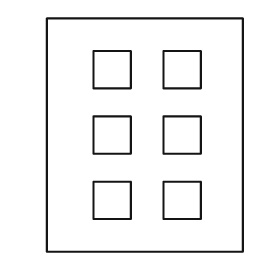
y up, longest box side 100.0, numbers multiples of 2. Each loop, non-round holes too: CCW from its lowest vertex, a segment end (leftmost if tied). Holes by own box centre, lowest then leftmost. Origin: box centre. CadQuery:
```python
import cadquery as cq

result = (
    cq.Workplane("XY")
    .moveTo(-42.0, -50.0)
    .lineTo(42.0, -50.0)
    .lineTo(42.0, 50.0)
    .lineTo(-42.0, 50.0)
    .close()
    .moveTo(-22.0, -36.0)
    .lineTo(-6.0, -36.0)
    .lineTo(-6.0, -20.0)
    .lineTo(-22.0, -20.0)
    .close()
    .moveTo(8.0, -36.0)
    .lineTo(24.0, -36.0)
    .lineTo(24.0, -20.0)
    .lineTo(8.0, -20.0)
    .close()
    .moveTo(-22.0, -8.0)
    .lineTo(-6.0, -8.0)
    .lineTo(-6.0, 8.0)
    .lineTo(-22.0, 8.0)
    .close()
    .moveTo(8.0, -8.0)
    .lineTo(24.0, -8.0)
    .lineTo(24.0, 8.0)
    .lineTo(8.0, 8.0)
    .close()
    .moveTo(-22.0, 20.0)
    .lineTo(-6.0, 20.0)
    .lineTo(-6.0, 36.0)
    .lineTo(-22.0, 36.0)
    .close()
    .moveTo(8.0, 20.0)
    .lineTo(24.0, 20.0)
    .lineTo(24.0, 36.0)
    .lineTo(8.0, 36.0)
    .close()
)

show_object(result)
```